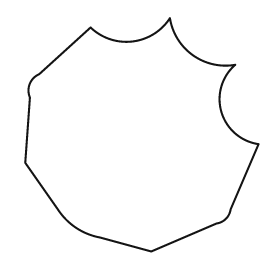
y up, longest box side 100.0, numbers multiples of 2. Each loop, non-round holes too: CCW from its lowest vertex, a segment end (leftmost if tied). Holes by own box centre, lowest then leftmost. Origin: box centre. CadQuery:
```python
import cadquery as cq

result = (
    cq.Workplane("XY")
    .moveTo(4.0, -50.0)
    .lineTo(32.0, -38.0)
    .threePointArc((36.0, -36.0), (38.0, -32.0))
    .lineTo(50.0, -4.0)
    .threePointArc((34.0, 10.0), (40.0, 30.0))
    .threePointArc((22.0, 34.0), (12.0, 50.0))
    .threePointArc((-4.0, 40.0), (-22.0, 46.0))
    .lineTo(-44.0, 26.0)
    .threePointArc((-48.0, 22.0), (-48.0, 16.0))
    .lineTo(-50.0, -12.0)
    .lineTo(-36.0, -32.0)
    .threePointArc((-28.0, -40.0), (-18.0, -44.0))
    .close()
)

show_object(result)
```